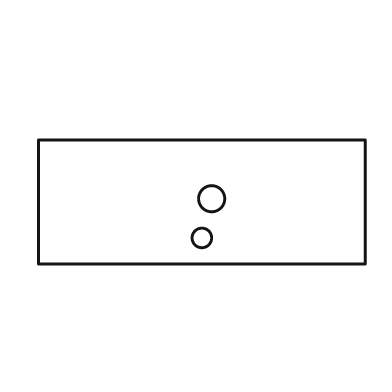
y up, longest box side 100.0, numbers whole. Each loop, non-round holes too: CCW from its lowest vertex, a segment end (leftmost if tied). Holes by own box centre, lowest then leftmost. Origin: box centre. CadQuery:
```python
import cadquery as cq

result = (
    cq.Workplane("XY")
    .moveTo(-50.0, -19.0)
    .lineTo(50.0, -19.0)
    .lineTo(50.0, 19.0)
    .lineTo(-50.0, 19.0)
    .close()
    .moveTo(0.0, -11.0)
    .circle(3.0)
    .moveTo(3.0, 1.0)
    .circle(4.0)
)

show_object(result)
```